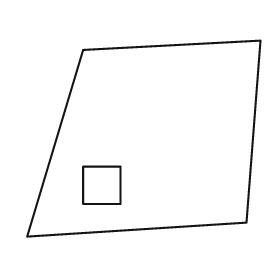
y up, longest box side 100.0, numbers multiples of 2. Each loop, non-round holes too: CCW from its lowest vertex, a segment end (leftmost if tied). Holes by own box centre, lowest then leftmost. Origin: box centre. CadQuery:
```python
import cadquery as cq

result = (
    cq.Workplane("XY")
    .moveTo(-50.0, -42.0)
    .lineTo(44.0, -36.0)
    .lineTo(50.0, 42.0)
    .lineTo(-26.0, 38.0)
    .close()
    .moveTo(-26.0, -28.0)
    .lineTo(-10.0, -28.0)
    .lineTo(-10.0, -12.0)
    .lineTo(-26.0, -12.0)
    .close()
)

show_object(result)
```